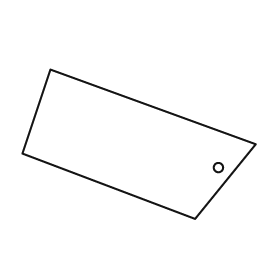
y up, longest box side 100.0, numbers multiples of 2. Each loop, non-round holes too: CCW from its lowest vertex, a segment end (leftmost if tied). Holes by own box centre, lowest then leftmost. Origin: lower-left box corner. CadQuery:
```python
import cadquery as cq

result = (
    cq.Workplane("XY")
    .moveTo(74.0, 0.0)
    .lineTo(100.0, 32.0)
    .lineTo(12.0, 64.0)
    .lineTo(0.0, 28.0)
    .close()
    .moveTo(84.0, 22.0)
    .circle(2.0)
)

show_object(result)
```